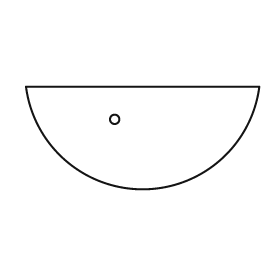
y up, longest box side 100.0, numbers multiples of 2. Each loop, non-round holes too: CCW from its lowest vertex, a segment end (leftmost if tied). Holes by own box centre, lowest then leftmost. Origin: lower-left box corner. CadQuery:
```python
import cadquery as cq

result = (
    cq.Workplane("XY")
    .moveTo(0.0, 44.0)
    .threePointArc((50.0, 0.0), (100.0, 44.0))
    .close()
    .moveTo(38.0, 30.0)
    .circle(2.0)
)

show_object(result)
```